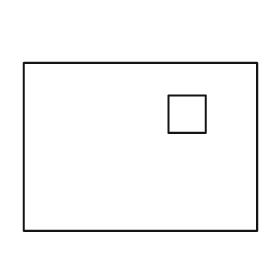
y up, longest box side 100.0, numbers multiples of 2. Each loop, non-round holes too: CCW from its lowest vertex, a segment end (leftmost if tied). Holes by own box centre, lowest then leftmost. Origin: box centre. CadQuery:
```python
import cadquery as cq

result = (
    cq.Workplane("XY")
    .moveTo(-50.0, -36.0)
    .lineTo(50.0, -36.0)
    .lineTo(50.0, 36.0)
    .lineTo(-50.0, 36.0)
    .close()
    .moveTo(12.0, 6.0)
    .lineTo(28.0, 6.0)
    .lineTo(28.0, 22.0)
    .lineTo(12.0, 22.0)
    .close()
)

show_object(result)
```